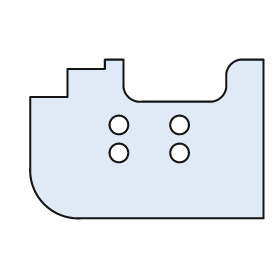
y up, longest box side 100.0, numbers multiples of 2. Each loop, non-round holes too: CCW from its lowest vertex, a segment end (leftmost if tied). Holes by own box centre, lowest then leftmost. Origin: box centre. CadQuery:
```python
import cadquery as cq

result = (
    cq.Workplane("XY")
    .moveTo(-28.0, -34.0)
    .lineTo(50.0, -34.0)
    .lineTo(50.0, 34.0)
    .lineTo(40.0, 34.0)
    .threePointArc((36.0, 32.0), (34.0, 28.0))
    .lineTo(34.0, 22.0)
    .threePointArc((32.0, 18.0), (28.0, 16.0))
    .lineTo(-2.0, 16.0)
    .threePointArc((-8.0, 18.0), (-10.0, 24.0))
    .lineTo(-10.0, 34.0)
    .lineTo(-18.0, 34.0)
    .lineTo(-18.0, 30.0)
    .lineTo(-34.0, 30.0)
    .lineTo(-34.0, 18.0)
    .lineTo(-50.0, 18.0)
    .lineTo(-50.0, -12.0)
    .threePointArc((-44.0, -28.0), (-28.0, -34.0))
    .close()
    .moveTo(-12.0, -6.0)
    .circle(4.0)
    .moveTo(14.0, -6.0)
    .circle(4.0)
    .moveTo(-12.0, 6.0)
    .circle(4.0)
    .moveTo(14.0, 6.0)
    .circle(4.0)
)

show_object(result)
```